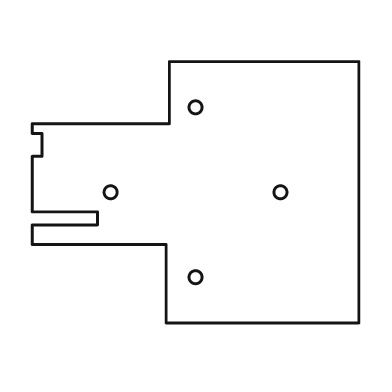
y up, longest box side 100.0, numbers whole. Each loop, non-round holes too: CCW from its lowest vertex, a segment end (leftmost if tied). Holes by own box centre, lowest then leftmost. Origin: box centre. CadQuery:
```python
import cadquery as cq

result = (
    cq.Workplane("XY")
    .moveTo(-9.0, -40.0)
    .lineTo(50.0, -40.0)
    .lineTo(50.0, 40.0)
    .lineTo(-8.0, 40.0)
    .lineTo(-8.0, 21.0)
    .lineTo(-50.0, 21.0)
    .lineTo(-50.0, 18.0)
    .lineTo(-47.0, 18.0)
    .lineTo(-47.0, 11.0)
    .lineTo(-50.0, 11.0)
    .lineTo(-50.0, -6.0)
    .lineTo(-30.0, -6.0)
    .lineTo(-30.0, -10.0)
    .lineTo(-50.0, -10.0)
    .lineTo(-50.0, -16.0)
    .lineTo(-9.0, -16.0)
    .close()
    .moveTo(0.0, -26.0)
    .circle(2.0)
    .moveTo(-26.0, 0.0)
    .circle(2.0)
    .moveTo(26.0, 0.0)
    .circle(2.0)
    .moveTo(0.0, 26.0)
    .circle(2.0)
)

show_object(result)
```